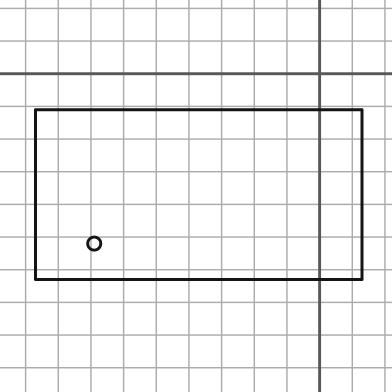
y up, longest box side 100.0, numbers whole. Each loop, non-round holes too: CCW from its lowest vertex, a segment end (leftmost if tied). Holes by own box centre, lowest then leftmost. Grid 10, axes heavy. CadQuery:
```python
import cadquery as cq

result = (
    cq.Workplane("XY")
    .moveTo(-87.0, -63.0)
    .lineTo(13.0, -63.0)
    .lineTo(13.0, -11.0)
    .lineTo(-87.0, -11.0)
    .close()
    .moveTo(-69.0, -52.0)
    .circle(2.0)
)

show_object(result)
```